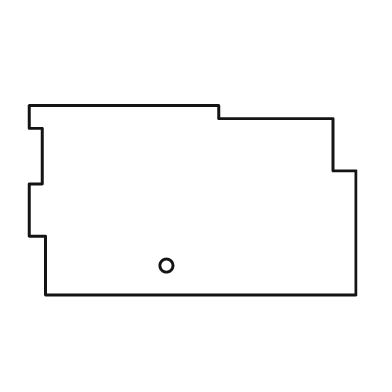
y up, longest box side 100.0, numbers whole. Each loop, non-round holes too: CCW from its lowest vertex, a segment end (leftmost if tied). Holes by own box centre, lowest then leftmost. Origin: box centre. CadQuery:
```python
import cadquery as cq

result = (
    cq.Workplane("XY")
    .moveTo(-45.0, -29.0)
    .lineTo(50.0, -29.0)
    .lineTo(50.0, 9.0)
    .lineTo(43.0, 9.0)
    .lineTo(43.0, 25.0)
    .lineTo(8.0, 25.0)
    .lineTo(8.0, 29.0)
    .lineTo(-50.0, 29.0)
    .lineTo(-50.0, 22.0)
    .lineTo(-46.0, 22.0)
    .lineTo(-46.0, 5.0)
    .lineTo(-50.0, 5.0)
    .lineTo(-50.0, -11.0)
    .lineTo(-45.0, -11.0)
    .close()
    .moveTo(-8.0, -20.0)
    .circle(2.0)
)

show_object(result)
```